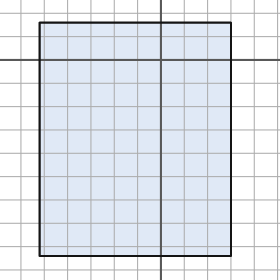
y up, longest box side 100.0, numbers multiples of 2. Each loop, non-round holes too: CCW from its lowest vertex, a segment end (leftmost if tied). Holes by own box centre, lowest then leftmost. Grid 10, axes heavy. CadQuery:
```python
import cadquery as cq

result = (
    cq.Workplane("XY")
    .moveTo(-52.0, -84.0)
    .lineTo(30.0, -84.0)
    .lineTo(30.0, 16.0)
    .lineTo(-52.0, 16.0)
    .close()
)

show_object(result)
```